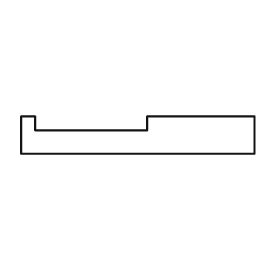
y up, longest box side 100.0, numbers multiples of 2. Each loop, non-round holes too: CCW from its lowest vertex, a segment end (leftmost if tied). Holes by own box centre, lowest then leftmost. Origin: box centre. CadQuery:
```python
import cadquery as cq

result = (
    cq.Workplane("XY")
    .moveTo(-50.0, -8.0)
    .lineTo(50.0, -8.0)
    .lineTo(50.0, 8.0)
    .lineTo(4.0, 8.0)
    .lineTo(4.0, 2.0)
    .lineTo(-44.0, 2.0)
    .lineTo(-44.0, 8.0)
    .lineTo(-50.0, 8.0)
    .close()
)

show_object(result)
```